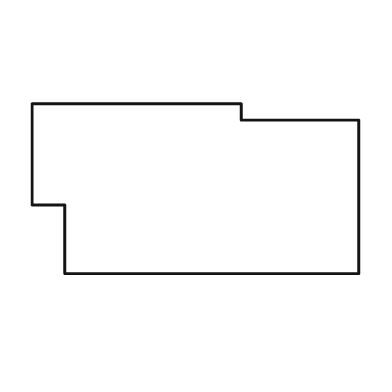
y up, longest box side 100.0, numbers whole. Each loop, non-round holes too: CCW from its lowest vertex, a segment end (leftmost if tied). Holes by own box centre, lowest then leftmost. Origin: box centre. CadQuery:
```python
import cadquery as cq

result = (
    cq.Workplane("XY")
    .moveTo(-40.0, -26.0)
    .lineTo(50.0, -26.0)
    .lineTo(50.0, 21.0)
    .lineTo(14.0, 21.0)
    .lineTo(14.0, 26.0)
    .lineTo(-50.0, 26.0)
    .lineTo(-50.0, -5.0)
    .lineTo(-40.0, -5.0)
    .close()
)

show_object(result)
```